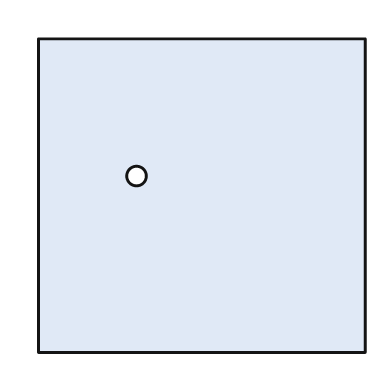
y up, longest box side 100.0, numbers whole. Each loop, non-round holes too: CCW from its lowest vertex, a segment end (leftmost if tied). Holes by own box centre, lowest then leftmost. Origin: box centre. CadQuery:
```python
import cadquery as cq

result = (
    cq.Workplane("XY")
    .moveTo(-50.0, -48.0)
    .lineTo(50.0, -48.0)
    .lineTo(50.0, 48.0)
    .lineTo(-50.0, 48.0)
    .close()
    .moveTo(-20.0, 6.0)
    .circle(3.0)
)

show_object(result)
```